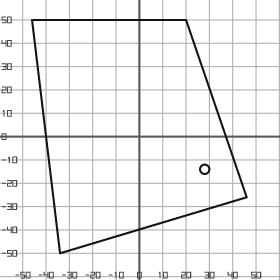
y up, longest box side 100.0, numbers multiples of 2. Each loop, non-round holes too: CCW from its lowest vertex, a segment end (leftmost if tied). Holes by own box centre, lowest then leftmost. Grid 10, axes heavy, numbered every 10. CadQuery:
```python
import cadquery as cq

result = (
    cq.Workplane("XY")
    .moveTo(-34.0, -50.0)
    .lineTo(46.0, -26.0)
    .lineTo(20.0, 50.0)
    .lineTo(-46.0, 50.0)
    .close()
    .moveTo(28.0, -14.0)
    .circle(2.0)
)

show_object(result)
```